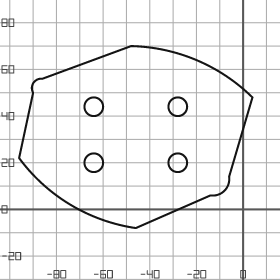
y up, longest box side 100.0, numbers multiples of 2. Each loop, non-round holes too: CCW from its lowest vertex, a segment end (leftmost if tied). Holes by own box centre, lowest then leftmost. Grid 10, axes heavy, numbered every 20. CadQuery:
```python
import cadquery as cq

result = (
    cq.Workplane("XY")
    .moveTo(-46.0, -8.0)
    .lineTo(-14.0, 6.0)
    .threePointArc((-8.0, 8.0), (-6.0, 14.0))
    .lineTo(4.0, 48.0)
    .threePointArc((-20.0, 64.0), (-48.0, 70.0))
    .lineTo(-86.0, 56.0)
    .threePointArc((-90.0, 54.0), (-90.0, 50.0))
    .lineTo(-96.0, 22.0)
    .threePointArc((-74.0, 2.0), (-46.0, -8.0))
    .close()
    .moveTo(-64.0, 20.0)
    .circle(4.0)
    .moveTo(-28.0, 20.0)
    .circle(4.0)
    .moveTo(-64.0, 44.0)
    .circle(4.0)
    .moveTo(-28.0, 44.0)
    .circle(4.0)
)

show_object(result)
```